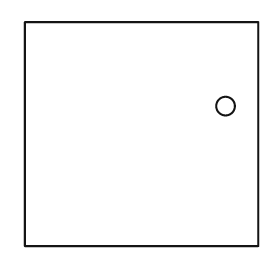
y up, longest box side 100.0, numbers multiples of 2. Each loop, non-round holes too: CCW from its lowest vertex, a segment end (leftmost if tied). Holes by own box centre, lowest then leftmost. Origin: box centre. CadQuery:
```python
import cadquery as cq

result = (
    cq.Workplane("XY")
    .moveTo(-50.0, -48.0)
    .lineTo(50.0, -48.0)
    .lineTo(50.0, 48.0)
    .lineTo(-50.0, 48.0)
    .close()
    .moveTo(36.0, 12.0)
    .circle(4.0)
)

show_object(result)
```